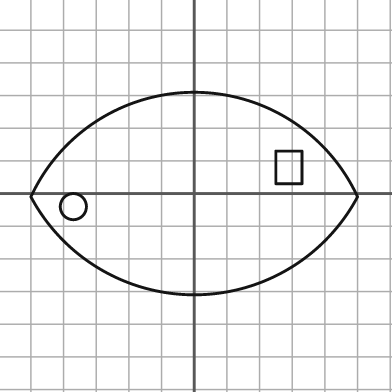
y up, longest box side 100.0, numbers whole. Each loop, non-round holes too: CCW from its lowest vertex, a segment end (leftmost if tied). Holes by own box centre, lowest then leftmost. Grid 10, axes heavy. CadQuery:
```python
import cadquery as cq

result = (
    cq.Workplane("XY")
    .moveTo(-50.0, -1.0)
    .threePointArc((0.0, -31.0), (50.0, -1.0))
    .threePointArc((0.0, 31.0), (-50.0, -1.0))
    .close()
    .moveTo(-37.0, -4.0)
    .circle(4.0)
    .moveTo(25.0, 3.0)
    .lineTo(33.0, 3.0)
    .lineTo(33.0, 13.0)
    .lineTo(25.0, 13.0)
    .close()
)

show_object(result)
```